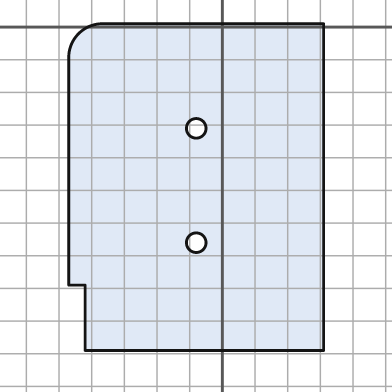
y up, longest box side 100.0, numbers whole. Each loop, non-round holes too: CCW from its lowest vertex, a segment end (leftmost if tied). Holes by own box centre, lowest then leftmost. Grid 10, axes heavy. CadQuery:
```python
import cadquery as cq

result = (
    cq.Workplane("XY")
    .moveTo(-42.0, -99.0)
    .lineTo(31.0, -99.0)
    .lineTo(31.0, 1.0)
    .lineTo(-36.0, 1.0)
    .threePointArc((-44.0, -2.0), (-47.0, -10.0))
    .lineTo(-47.0, -79.0)
    .lineTo(-42.0, -79.0)
    .close()
    .moveTo(-8.0, -66.0)
    .circle(3.0)
    .moveTo(-8.0, -31.0)
    .circle(3.0)
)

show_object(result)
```